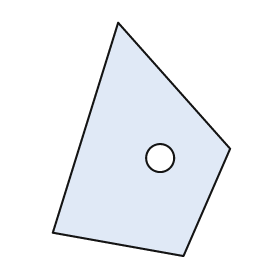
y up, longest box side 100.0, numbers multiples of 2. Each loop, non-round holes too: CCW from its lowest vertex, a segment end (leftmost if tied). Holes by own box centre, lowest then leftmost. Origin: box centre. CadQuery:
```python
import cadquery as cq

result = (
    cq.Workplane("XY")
    .moveTo(18.0, -50.0)
    .lineTo(38.0, -4.0)
    .lineTo(-10.0, 50.0)
    .lineTo(-38.0, -40.0)
    .close()
    .moveTo(8.0, -8.0)
    .circle(6.0)
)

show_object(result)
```